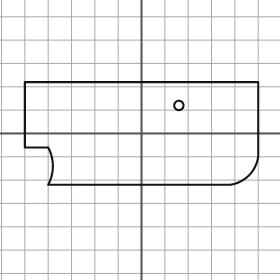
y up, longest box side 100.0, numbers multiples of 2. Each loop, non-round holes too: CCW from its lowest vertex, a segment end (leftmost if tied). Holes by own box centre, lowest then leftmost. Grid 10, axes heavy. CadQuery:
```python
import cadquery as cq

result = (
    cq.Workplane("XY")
    .moveTo(-40.0, -22.0)
    .lineTo(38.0, -22.0)
    .threePointArc((46.0, -18.0), (50.0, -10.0))
    .lineTo(50.0, 22.0)
    .lineTo(-50.0, 22.0)
    .lineTo(-50.0, -6.0)
    .lineTo(-40.0, -6.0)
    .threePointArc((-38.0, -14.0), (-40.0, -22.0))
    .close()
    .moveTo(16.0, 12.0)
    .circle(2.0)
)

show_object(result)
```